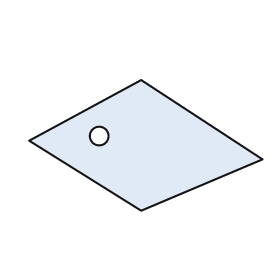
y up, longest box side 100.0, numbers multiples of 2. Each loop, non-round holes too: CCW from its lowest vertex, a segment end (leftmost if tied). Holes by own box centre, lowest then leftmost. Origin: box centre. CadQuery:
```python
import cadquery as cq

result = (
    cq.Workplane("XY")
    .moveTo(-2.0, -28.0)
    .lineTo(50.0, -6.0)
    .lineTo(-2.0, 28.0)
    .lineTo(-50.0, 2.0)
    .close()
    .moveTo(-20.0, 4.0)
    .circle(4.0)
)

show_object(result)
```